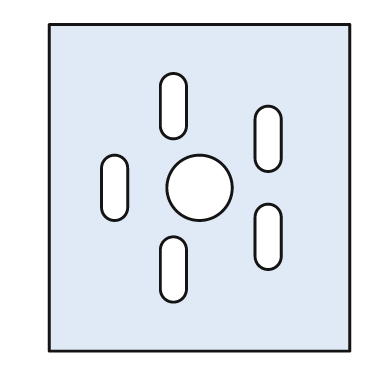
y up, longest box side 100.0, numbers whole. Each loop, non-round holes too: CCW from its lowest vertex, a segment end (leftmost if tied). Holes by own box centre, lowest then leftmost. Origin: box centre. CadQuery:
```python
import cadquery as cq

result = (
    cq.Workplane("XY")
    .moveTo(-46.0, -50.0)
    .lineTo(46.0, -50.0)
    .lineTo(46.0, 50.0)
    .lineTo(-46.0, 50.0)
    .close()
    .moveTo(-12.0, -31.0)
    .threePointArc((-8.0, -35.0), (-4.0, -31.0))
    .lineTo(-4.0, -19.0)
    .threePointArc((-8.0, -15.0), (-12.0, -19.0))
    .close()
    .moveTo(17.0, -21.0)
    .threePointArc((21.0, -25.0), (25.0, -21.0))
    .lineTo(25.0, -9.0)
    .threePointArc((21.0, -5.0), (17.0, -9.0))
    .close()
    .moveTo(-30.0, -6.0)
    .threePointArc((-26.0, -10.0), (-22.0, -6.0))
    .lineTo(-22.0, 6.0)
    .threePointArc((-26.0, 10.0), (-30.0, 6.0))
    .close()
    .moveTo(0.0, 0.0)
    .circle(10.0)
    .moveTo(17.0, 9.0)
    .threePointArc((21.0, 5.0), (25.0, 9.0))
    .lineTo(25.0, 21.0)
    .threePointArc((21.0, 25.0), (17.0, 21.0))
    .close()
    .moveTo(-12.0, 19.0)
    .threePointArc((-8.0, 15.0), (-4.0, 19.0))
    .lineTo(-4.0, 31.0)
    .threePointArc((-8.0, 35.0), (-12.0, 31.0))
    .close()
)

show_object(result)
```